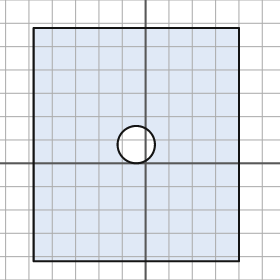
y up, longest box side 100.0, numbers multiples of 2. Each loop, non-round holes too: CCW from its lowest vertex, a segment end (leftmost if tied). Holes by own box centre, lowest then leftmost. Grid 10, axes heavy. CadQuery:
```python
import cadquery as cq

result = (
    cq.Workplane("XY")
    .moveTo(-48.0, -42.0)
    .lineTo(40.0, -42.0)
    .lineTo(40.0, 58.0)
    .lineTo(-48.0, 58.0)
    .close()
    .moveTo(-4.0, 8.0)
    .circle(8.0)
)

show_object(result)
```